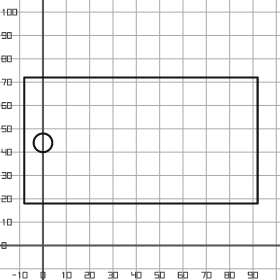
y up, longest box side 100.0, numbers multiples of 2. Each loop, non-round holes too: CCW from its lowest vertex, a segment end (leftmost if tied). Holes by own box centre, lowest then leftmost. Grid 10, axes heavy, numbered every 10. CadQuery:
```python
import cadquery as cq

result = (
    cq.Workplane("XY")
    .moveTo(-8.0, 18.0)
    .lineTo(92.0, 18.0)
    .lineTo(92.0, 72.0)
    .lineTo(-8.0, 72.0)
    .close()
    .moveTo(0.0, 44.0)
    .circle(4.0)
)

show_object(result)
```